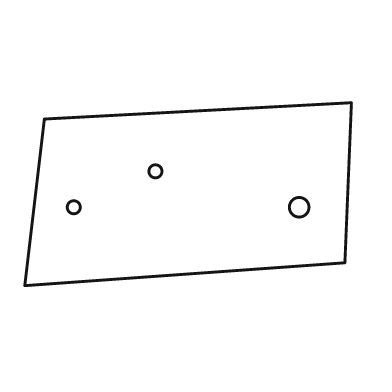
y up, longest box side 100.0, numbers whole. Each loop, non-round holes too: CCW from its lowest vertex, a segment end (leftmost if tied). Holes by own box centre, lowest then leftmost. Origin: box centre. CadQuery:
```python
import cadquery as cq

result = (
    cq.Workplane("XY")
    .moveTo(-50.0, -28.0)
    .lineTo(48.0, -21.0)
    .lineTo(50.0, 28.0)
    .lineTo(-44.0, 23.0)
    .close()
    .moveTo(-35.0, -4.0)
    .circle(2.0)
    .moveTo(34.0, -4.0)
    .circle(3.0)
    .moveTo(-10.0, 7.0)
    .circle(2.0)
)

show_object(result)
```